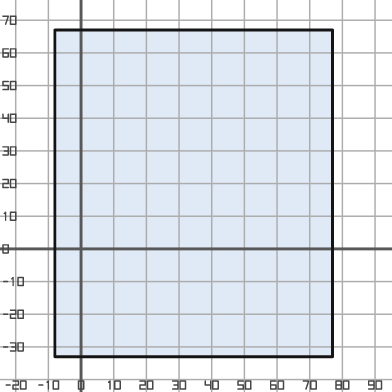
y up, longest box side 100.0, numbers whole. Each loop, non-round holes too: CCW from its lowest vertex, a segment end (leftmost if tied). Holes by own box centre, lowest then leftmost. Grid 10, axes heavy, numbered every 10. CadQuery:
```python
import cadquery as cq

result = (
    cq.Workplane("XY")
    .moveTo(-8.0, -33.0)
    .lineTo(77.0, -33.0)
    .lineTo(77.0, 67.0)
    .lineTo(-8.0, 67.0)
    .close()
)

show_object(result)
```